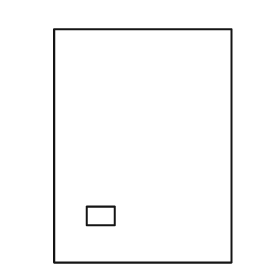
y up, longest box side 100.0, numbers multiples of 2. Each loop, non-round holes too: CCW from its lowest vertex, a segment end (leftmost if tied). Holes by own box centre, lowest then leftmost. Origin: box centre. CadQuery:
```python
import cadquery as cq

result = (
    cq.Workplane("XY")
    .moveTo(-38.0, -50.0)
    .lineTo(38.0, -50.0)
    .lineTo(38.0, 50.0)
    .lineTo(-38.0, 50.0)
    .close()
    .moveTo(-24.0, -34.0)
    .lineTo(-12.0, -34.0)
    .lineTo(-12.0, -26.0)
    .lineTo(-24.0, -26.0)
    .close()
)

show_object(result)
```